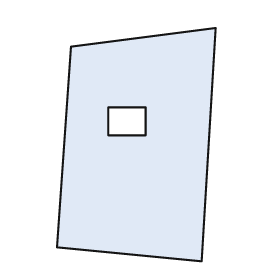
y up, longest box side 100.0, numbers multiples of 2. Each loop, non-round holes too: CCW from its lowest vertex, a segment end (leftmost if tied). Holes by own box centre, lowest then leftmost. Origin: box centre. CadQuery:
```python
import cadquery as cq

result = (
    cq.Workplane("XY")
    .moveTo(28.0, -50.0)
    .lineTo(34.0, 50.0)
    .lineTo(-28.0, 42.0)
    .lineTo(-34.0, -44.0)
    .close()
    .moveTo(-12.0, 4.0)
    .lineTo(4.0, 4.0)
    .lineTo(4.0, 16.0)
    .lineTo(-12.0, 16.0)
    .close()
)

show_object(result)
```